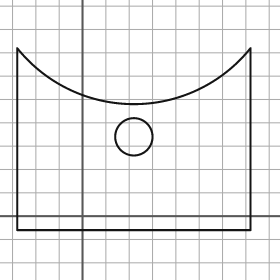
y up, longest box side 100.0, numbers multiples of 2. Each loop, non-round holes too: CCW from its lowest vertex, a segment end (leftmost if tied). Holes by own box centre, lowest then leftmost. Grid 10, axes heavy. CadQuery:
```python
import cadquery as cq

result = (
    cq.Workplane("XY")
    .moveTo(-28.0, -6.0)
    .lineTo(72.0, -6.0)
    .lineTo(72.0, 72.0)
    .threePointArc((22.0, 48.0), (-28.0, 72.0))
    .close()
    .moveTo(22.0, 34.0)
    .circle(8.0)
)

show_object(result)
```